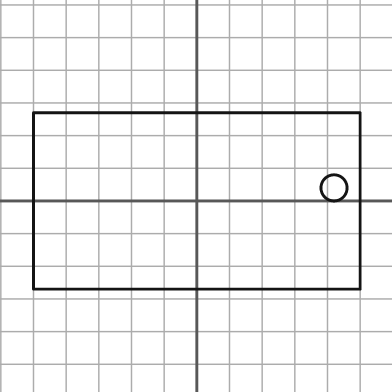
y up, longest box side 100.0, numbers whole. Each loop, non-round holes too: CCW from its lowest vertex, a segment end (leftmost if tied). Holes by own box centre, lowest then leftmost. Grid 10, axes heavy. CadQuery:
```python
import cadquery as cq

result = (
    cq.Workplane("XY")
    .moveTo(-50.0, -27.0)
    .lineTo(50.0, -27.0)
    .lineTo(50.0, 27.0)
    .lineTo(-50.0, 27.0)
    .close()
    .moveTo(42.0, 4.0)
    .circle(4.0)
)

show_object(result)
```